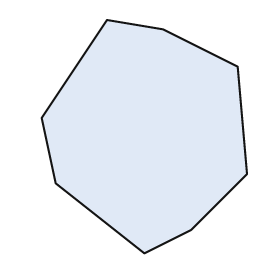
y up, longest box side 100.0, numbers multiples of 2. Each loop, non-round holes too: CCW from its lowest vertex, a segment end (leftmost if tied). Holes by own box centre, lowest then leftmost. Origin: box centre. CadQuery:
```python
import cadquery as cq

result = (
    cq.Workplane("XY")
    .moveTo(0.0, -50.0)
    .lineTo(20.0, -40.0)
    .lineTo(44.0, -16.0)
    .lineTo(40.0, 30.0)
    .lineTo(8.0, 46.0)
    .lineTo(-16.0, 50.0)
    .lineTo(-44.0, 8.0)
    .lineTo(-38.0, -20.0)
    .close()
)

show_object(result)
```